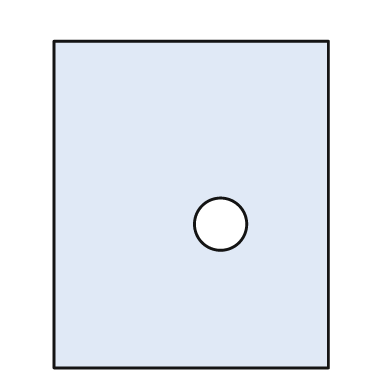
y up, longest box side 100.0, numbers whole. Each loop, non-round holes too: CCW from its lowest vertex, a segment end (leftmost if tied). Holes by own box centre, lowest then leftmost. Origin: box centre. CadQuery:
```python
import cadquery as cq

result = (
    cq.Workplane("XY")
    .moveTo(-42.0, -50.0)
    .lineTo(42.0, -50.0)
    .lineTo(42.0, 50.0)
    .lineTo(-42.0, 50.0)
    .close()
    .moveTo(9.0, -6.0)
    .circle(8.0)
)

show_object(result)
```